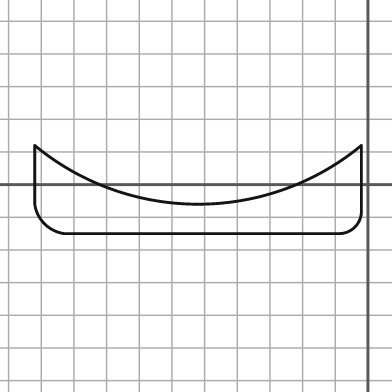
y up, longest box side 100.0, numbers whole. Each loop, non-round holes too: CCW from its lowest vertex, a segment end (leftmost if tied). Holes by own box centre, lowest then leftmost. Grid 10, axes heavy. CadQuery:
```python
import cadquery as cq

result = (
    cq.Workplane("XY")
    .moveTo(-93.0, -15.0)
    .lineTo(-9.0, -15.0)
    .threePointArc((-4.0, -13.0), (-2.0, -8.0))
    .lineTo(-2.0, 12.0)
    .threePointArc((-52.0, -6.0), (-102.0, 12.0))
    .lineTo(-102.0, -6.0)
    .threePointArc((-99.0, -12.0), (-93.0, -15.0))
    .close()
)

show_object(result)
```